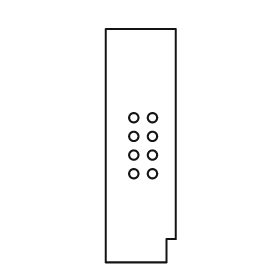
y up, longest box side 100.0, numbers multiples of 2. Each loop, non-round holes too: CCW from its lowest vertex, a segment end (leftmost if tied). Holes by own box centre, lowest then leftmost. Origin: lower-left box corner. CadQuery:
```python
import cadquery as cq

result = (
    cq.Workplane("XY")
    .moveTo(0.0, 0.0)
    .lineTo(26.0, 0.0)
    .lineTo(26.0, 10.0)
    .lineTo(30.0, 10.0)
    .lineTo(30.0, 100.0)
    .lineTo(0.0, 100.0)
    .close()
    .moveTo(12.0, 38.0)
    .circle(2.0)
    .moveTo(20.0, 38.0)
    .circle(2.0)
    .moveTo(12.0, 46.0)
    .circle(2.0)
    .moveTo(20.0, 46.0)
    .circle(2.0)
    .moveTo(12.0, 54.0)
    .circle(2.0)
    .moveTo(20.0, 54.0)
    .circle(2.0)
    .moveTo(12.0, 62.0)
    .circle(2.0)
    .moveTo(20.0, 62.0)
    .circle(2.0)
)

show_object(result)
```